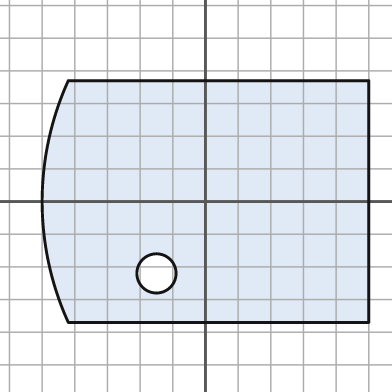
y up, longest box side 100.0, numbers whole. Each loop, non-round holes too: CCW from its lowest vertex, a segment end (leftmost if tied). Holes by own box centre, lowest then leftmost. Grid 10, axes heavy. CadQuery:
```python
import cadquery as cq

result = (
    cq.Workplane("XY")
    .moveTo(-42.0, -37.0)
    .lineTo(50.0, -37.0)
    .lineTo(50.0, 37.0)
    .lineTo(-42.0, 37.0)
    .threePointArc((-50.0, 0.0), (-42.0, -37.0))
    .close()
    .moveTo(-15.0, -22.0)
    .circle(6.0)
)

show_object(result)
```